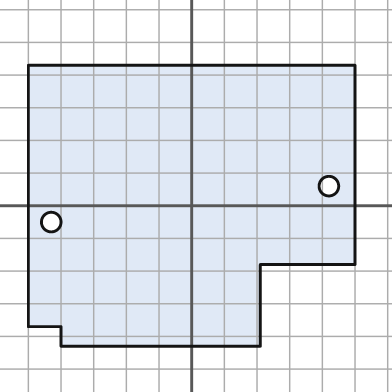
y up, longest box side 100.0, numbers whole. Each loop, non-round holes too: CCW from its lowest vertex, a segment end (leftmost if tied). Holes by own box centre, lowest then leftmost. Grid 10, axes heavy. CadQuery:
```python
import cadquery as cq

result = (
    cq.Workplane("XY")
    .moveTo(-40.0, -43.0)
    .lineTo(21.0, -43.0)
    .lineTo(21.0, -18.0)
    .lineTo(50.0, -18.0)
    .lineTo(50.0, 43.0)
    .lineTo(-50.0, 43.0)
    .lineTo(-50.0, -37.0)
    .lineTo(-40.0, -37.0)
    .close()
    .moveTo(-43.0, -5.0)
    .circle(3.0)
    .moveTo(42.0, 6.0)
    .circle(3.0)
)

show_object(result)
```